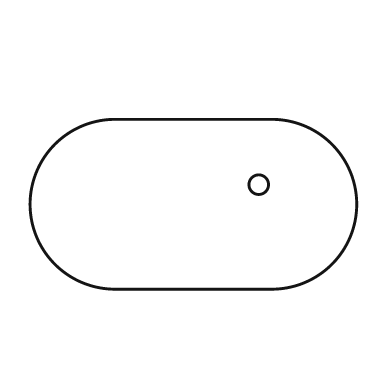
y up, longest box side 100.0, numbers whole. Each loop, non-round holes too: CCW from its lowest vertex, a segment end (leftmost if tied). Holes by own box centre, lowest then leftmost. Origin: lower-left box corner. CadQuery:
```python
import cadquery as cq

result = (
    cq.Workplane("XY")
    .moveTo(26.0, 0.0)
    .lineTo(74.0, 0.0)
    .threePointArc((100.0, 26.0), (74.0, 52.0))
    .lineTo(26.0, 52.0)
    .threePointArc((0.0, 26.0), (26.0, 0.0))
    .close()
    .moveTo(70.0, 32.0)
    .circle(3.0)
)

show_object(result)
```